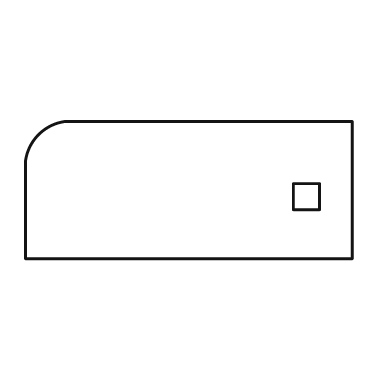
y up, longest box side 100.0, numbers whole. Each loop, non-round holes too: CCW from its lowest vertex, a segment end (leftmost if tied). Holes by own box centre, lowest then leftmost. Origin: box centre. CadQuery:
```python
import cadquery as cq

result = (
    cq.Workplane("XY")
    .moveTo(-50.0, -21.0)
    .lineTo(50.0, -21.0)
    .lineTo(50.0, 21.0)
    .lineTo(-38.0, 21.0)
    .threePointArc((-46.0, 17.0), (-50.0, 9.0))
    .close()
    .moveTo(32.0, -6.0)
    .lineTo(40.0, -6.0)
    .lineTo(40.0, 2.0)
    .lineTo(32.0, 2.0)
    .close()
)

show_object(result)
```